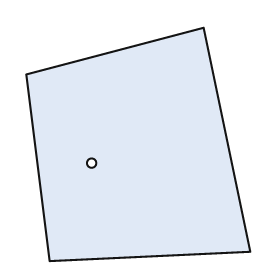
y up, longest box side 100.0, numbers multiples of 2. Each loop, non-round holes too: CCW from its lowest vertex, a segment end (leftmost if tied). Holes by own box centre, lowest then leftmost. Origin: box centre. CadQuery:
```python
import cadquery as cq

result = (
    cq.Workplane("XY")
    .moveTo(-38.0, -50.0)
    .lineTo(48.0, -46.0)
    .lineTo(28.0, 50.0)
    .lineTo(-48.0, 30.0)
    .close()
    .moveTo(-20.0, -8.0)
    .circle(2.0)
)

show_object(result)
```